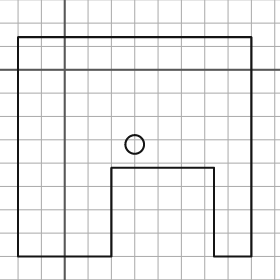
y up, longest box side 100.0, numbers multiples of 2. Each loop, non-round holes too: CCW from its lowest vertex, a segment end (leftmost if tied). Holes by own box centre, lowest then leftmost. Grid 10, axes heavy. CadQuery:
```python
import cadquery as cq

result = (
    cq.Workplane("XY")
    .moveTo(-20.0, -80.0)
    .lineTo(20.0, -80.0)
    .lineTo(20.0, -42.0)
    .lineTo(64.0, -42.0)
    .lineTo(64.0, -80.0)
    .lineTo(80.0, -80.0)
    .lineTo(80.0, 14.0)
    .lineTo(-20.0, 14.0)
    .close()
    .moveTo(30.0, -32.0)
    .circle(4.0)
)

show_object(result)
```